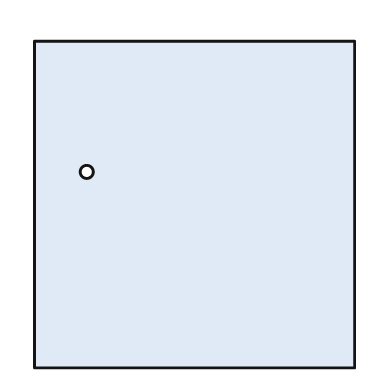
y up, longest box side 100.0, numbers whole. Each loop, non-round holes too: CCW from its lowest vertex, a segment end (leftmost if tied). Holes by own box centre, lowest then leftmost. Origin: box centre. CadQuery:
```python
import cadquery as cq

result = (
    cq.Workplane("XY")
    .moveTo(-49.0, -50.0)
    .lineTo(49.0, -50.0)
    .lineTo(49.0, 50.0)
    .lineTo(-49.0, 50.0)
    .close()
    .moveTo(-33.0, 10.0)
    .circle(2.0)
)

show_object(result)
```